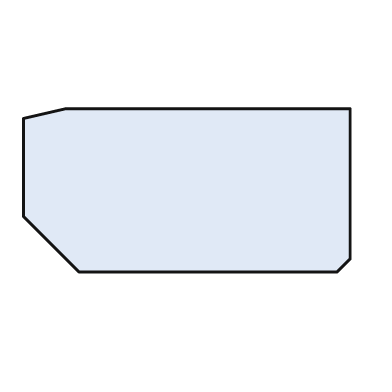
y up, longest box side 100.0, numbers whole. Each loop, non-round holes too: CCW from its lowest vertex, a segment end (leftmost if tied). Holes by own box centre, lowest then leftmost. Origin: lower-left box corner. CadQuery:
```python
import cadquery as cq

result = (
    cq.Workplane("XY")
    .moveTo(17.0, 0.0)
    .lineTo(96.0, 0.0)
    .lineTo(100.0, 4.0)
    .lineTo(100.0, 50.0)
    .lineTo(13.0, 50.0)
    .lineTo(0.0, 47.0)
    .lineTo(0.0, 17.0)
    .close()
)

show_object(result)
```